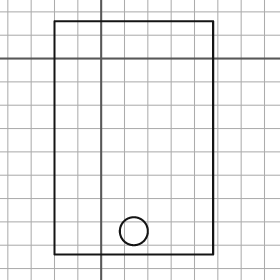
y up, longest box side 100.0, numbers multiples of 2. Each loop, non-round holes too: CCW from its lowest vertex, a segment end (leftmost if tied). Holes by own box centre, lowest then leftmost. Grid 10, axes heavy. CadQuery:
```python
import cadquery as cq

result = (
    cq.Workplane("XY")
    .moveTo(-20.0, -84.0)
    .lineTo(48.0, -84.0)
    .lineTo(48.0, 16.0)
    .lineTo(-20.0, 16.0)
    .close()
    .moveTo(14.0, -74.0)
    .circle(6.0)
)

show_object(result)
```